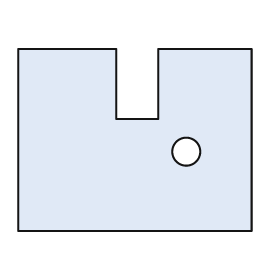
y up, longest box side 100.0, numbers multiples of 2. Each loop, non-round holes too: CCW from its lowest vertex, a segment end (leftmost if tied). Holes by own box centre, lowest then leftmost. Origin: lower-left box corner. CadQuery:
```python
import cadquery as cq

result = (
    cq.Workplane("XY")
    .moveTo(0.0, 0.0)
    .lineTo(100.0, 0.0)
    .lineTo(100.0, 78.0)
    .lineTo(60.0, 78.0)
    .lineTo(60.0, 48.0)
    .lineTo(42.0, 48.0)
    .lineTo(42.0, 78.0)
    .lineTo(0.0, 78.0)
    .close()
    .moveTo(72.0, 34.0)
    .circle(6.0)
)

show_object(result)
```